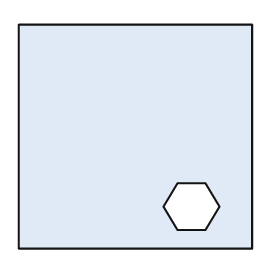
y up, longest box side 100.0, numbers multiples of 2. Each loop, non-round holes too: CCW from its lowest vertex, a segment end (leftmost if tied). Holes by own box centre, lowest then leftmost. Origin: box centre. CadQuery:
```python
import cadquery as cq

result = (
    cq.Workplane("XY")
    .moveTo(-50.0, -48.0)
    .lineTo(50.0, -48.0)
    .lineTo(50.0, 48.0)
    .lineTo(-50.0, 48.0)
    .close()
    .moveTo(18.0, -40.0)
    .lineTo(30.0, -40.0)
    .lineTo(36.0, -30.0)
    .lineTo(30.0, -20.0)
    .lineTo(18.0, -20.0)
    .lineTo(12.0, -30.0)
    .close()
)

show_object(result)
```